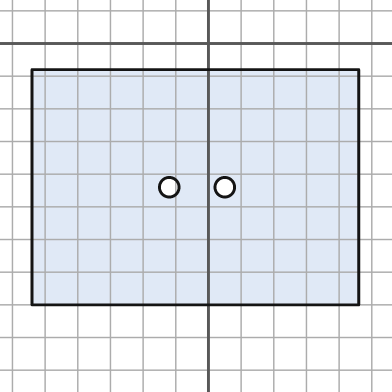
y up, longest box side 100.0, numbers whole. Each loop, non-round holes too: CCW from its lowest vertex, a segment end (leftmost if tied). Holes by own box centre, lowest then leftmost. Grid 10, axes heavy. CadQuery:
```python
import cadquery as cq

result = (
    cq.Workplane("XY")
    .moveTo(-54.0, -80.0)
    .lineTo(46.0, -80.0)
    .lineTo(46.0, -8.0)
    .lineTo(-54.0, -8.0)
    .close()
    .moveTo(-12.0, -44.0)
    .circle(3.0)
    .moveTo(5.0, -44.0)
    .circle(3.0)
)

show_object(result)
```